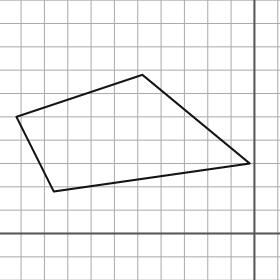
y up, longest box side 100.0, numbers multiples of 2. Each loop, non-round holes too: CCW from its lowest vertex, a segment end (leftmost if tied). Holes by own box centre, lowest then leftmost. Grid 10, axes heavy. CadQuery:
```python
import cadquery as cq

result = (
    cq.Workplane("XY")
    .moveTo(-86.0, 18.0)
    .lineTo(-2.0, 30.0)
    .lineTo(-48.0, 68.0)
    .lineTo(-102.0, 50.0)
    .close()
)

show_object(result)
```